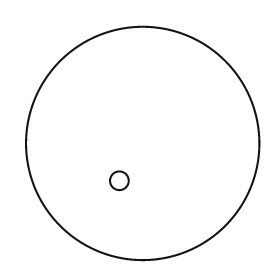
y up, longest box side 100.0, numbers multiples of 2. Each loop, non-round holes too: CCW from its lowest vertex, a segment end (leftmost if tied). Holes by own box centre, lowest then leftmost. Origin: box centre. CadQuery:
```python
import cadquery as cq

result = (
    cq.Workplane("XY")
    .moveTo(0.0, 0.0)
    .circle(50.0)
    .moveTo(-10.0, -16.0)
    .circle(4.0)
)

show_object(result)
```